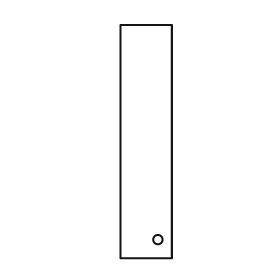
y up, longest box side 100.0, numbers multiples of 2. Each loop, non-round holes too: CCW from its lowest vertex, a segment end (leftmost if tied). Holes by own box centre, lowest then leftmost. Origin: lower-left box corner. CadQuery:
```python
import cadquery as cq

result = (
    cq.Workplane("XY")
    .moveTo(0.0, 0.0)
    .lineTo(22.0, 0.0)
    .lineTo(22.0, 100.0)
    .lineTo(0.0, 100.0)
    .close()
    .moveTo(16.0, 8.0)
    .circle(2.0)
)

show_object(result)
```